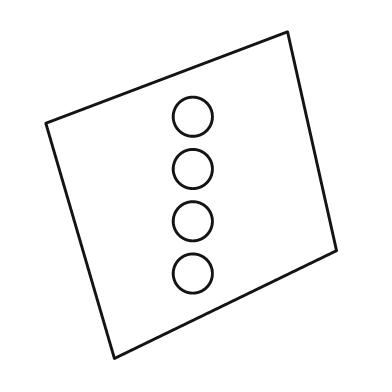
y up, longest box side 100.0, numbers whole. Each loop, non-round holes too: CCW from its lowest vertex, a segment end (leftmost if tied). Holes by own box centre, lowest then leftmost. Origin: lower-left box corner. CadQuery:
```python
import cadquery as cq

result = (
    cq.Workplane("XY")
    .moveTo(21.0, 0.0)
    .lineTo(89.0, 33.0)
    .lineTo(74.0, 100.0)
    .lineTo(0.0, 72.0)
    .close()
    .moveTo(45.0, 26.0)
    .circle(6.0)
    .moveTo(45.0, 42.0)
    .circle(6.0)
    .moveTo(45.0, 58.0)
    .circle(6.0)
    .moveTo(45.0, 74.0)
    .circle(6.0)
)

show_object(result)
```